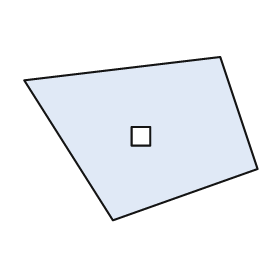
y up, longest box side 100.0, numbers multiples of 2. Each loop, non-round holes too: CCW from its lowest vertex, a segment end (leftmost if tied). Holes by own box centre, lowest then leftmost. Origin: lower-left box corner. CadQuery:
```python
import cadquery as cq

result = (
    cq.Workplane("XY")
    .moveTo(38.0, 0.0)
    .lineTo(100.0, 22.0)
    .lineTo(84.0, 70.0)
    .lineTo(0.0, 60.0)
    .close()
    .moveTo(46.0, 32.0)
    .lineTo(54.0, 32.0)
    .lineTo(54.0, 40.0)
    .lineTo(46.0, 40.0)
    .close()
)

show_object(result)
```